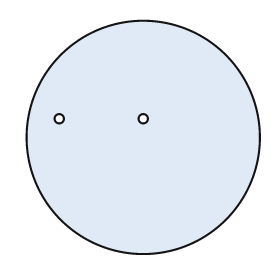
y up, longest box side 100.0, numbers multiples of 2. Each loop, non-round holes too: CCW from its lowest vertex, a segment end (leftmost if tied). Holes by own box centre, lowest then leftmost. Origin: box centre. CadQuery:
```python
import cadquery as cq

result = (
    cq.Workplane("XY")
    .moveTo(0.0, 0.0)
    .circle(50.0)
    .moveTo(-36.0, 8.0)
    .circle(2.0)
    .moveTo(0.0, 8.0)
    .circle(2.0)
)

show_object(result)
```